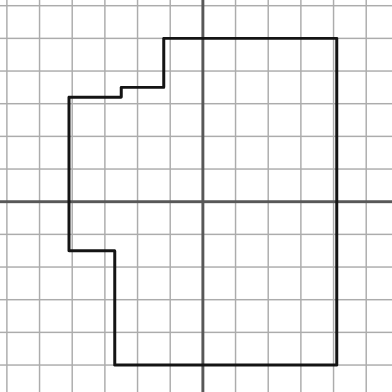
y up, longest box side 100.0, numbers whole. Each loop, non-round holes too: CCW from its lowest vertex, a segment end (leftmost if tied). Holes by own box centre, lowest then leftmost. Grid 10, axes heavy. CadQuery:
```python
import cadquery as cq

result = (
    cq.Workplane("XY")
    .moveTo(-27.0, -50.0)
    .lineTo(41.0, -50.0)
    .lineTo(41.0, 50.0)
    .lineTo(-12.0, 50.0)
    .lineTo(-12.0, 35.0)
    .lineTo(-25.0, 35.0)
    .lineTo(-25.0, 32.0)
    .lineTo(-41.0, 32.0)
    .lineTo(-41.0, -15.0)
    .lineTo(-27.0, -15.0)
    .close()
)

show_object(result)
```